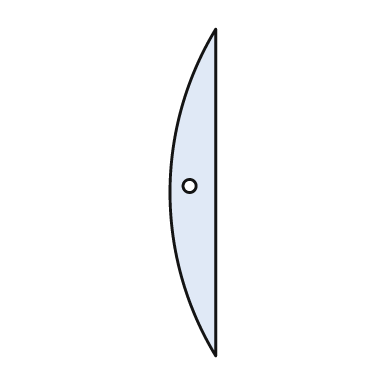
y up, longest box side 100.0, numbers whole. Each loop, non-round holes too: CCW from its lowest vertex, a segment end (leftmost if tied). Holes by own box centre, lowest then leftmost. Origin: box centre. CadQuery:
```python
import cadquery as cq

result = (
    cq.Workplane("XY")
    .moveTo(7.0, -50.0)
    .lineTo(7.0, 50.0)
    .threePointArc((-7.0, 0.0), (7.0, -50.0))
    .close()
    .moveTo(-1.0, 2.0)
    .circle(2.0)
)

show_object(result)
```